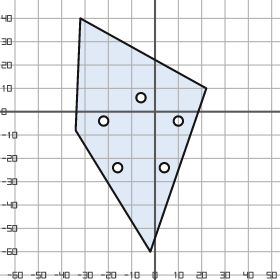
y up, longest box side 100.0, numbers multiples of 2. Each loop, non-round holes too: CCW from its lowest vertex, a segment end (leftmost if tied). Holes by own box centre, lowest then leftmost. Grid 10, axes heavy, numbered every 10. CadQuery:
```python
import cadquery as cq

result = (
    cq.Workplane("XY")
    .moveTo(-2.0, -60.0)
    .lineTo(22.0, 10.0)
    .lineTo(-32.0, 40.0)
    .lineTo(-34.0, -8.0)
    .close()
    .moveTo(-16.0, -24.0)
    .circle(2.0)
    .moveTo(4.0, -24.0)
    .circle(2.0)
    .moveTo(-22.0, -4.0)
    .circle(2.0)
    .moveTo(10.0, -4.0)
    .circle(2.0)
    .moveTo(-6.0, 6.0)
    .circle(2.0)
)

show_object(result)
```